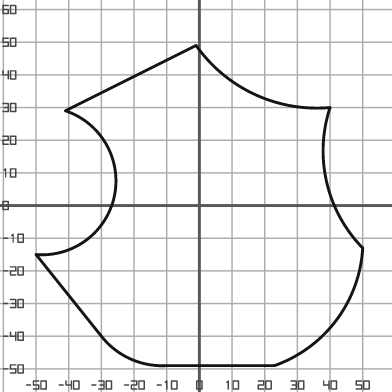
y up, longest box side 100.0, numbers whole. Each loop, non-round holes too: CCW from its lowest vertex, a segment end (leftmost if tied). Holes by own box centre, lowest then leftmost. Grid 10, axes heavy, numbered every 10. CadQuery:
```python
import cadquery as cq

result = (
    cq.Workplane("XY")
    .moveTo(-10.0, -49.0)
    .lineTo(23.0, -49.0)
    .threePointArc((42.0, -35.0), (50.0, -13.0))
    .threePointArc((39.0, 7.0), (40.0, 30.0))
    .threePointArc((17.0, 34.0), (-1.0, 49.0))
    .lineTo(-41.0, 29.0)
    .threePointArc((-26.0, 3.0), (-50.0, -15.0))
    .lineTo(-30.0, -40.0)
    .threePointArc((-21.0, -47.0), (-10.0, -49.0))
    .close()
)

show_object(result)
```